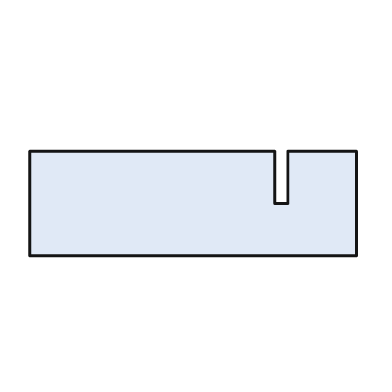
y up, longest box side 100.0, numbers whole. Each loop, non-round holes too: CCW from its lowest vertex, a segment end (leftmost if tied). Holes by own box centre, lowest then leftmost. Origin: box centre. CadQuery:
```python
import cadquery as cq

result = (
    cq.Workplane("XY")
    .moveTo(-50.0, -16.0)
    .lineTo(50.0, -16.0)
    .lineTo(50.0, 16.0)
    .lineTo(29.0, 16.0)
    .lineTo(29.0, 0.0)
    .lineTo(25.0, 0.0)
    .lineTo(25.0, 16.0)
    .lineTo(-50.0, 16.0)
    .close()
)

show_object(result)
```